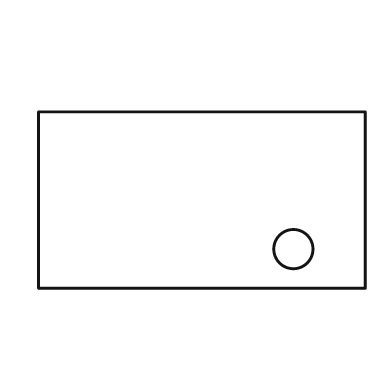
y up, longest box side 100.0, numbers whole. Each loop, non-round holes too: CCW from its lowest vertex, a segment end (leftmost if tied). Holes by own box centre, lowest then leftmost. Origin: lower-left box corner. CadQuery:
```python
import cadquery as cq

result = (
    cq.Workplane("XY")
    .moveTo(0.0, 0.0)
    .lineTo(100.0, 0.0)
    .lineTo(100.0, 54.0)
    .lineTo(0.0, 54.0)
    .close()
    .moveTo(78.0, 12.0)
    .circle(6.0)
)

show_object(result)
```